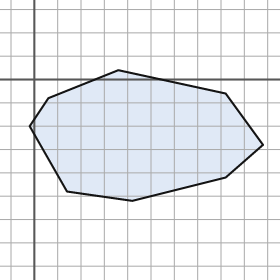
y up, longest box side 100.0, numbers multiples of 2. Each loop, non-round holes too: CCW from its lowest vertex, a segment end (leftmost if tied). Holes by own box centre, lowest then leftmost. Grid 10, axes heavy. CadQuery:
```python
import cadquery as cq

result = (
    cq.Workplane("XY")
    .moveTo(42.0, -52.0)
    .lineTo(82.0, -42.0)
    .lineTo(98.0, -28.0)
    .lineTo(82.0, -6.0)
    .lineTo(36.0, 4.0)
    .lineTo(6.0, -8.0)
    .lineTo(-2.0, -20.0)
    .lineTo(14.0, -48.0)
    .close()
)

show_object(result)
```